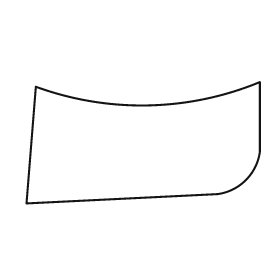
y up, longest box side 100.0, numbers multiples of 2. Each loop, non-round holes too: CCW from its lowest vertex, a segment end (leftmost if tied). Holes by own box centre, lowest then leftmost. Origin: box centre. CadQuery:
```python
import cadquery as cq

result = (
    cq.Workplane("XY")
    .moveTo(-50.0, -26.0)
    .lineTo(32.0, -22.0)
    .threePointArc((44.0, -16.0), (50.0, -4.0))
    .lineTo(50.0, 26.0)
    .threePointArc((2.0, 16.0), (-46.0, 24.0))
    .close()
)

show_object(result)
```